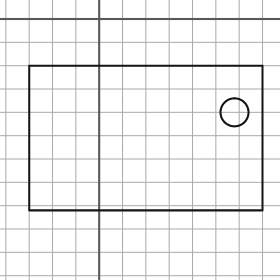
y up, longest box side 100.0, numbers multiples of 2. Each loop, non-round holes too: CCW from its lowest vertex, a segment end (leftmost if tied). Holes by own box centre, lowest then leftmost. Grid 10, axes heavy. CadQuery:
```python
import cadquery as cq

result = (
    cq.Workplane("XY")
    .moveTo(-30.0, -82.0)
    .lineTo(70.0, -82.0)
    .lineTo(70.0, -20.0)
    .lineTo(-30.0, -20.0)
    .close()
    .moveTo(58.0, -40.0)
    .circle(6.0)
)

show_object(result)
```